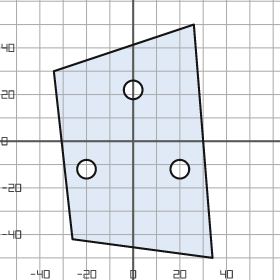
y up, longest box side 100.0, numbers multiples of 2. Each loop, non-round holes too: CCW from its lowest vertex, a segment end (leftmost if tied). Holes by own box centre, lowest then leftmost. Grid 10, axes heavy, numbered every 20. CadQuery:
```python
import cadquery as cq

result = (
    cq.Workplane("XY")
    .moveTo(34.0, -50.0)
    .lineTo(26.0, 50.0)
    .lineTo(-34.0, 30.0)
    .lineTo(-26.0, -42.0)
    .close()
    .moveTo(-20.0, -12.0)
    .circle(4.0)
    .moveTo(20.0, -12.0)
    .circle(4.0)
    .moveTo(0.0, 22.0)
    .circle(4.0)
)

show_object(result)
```